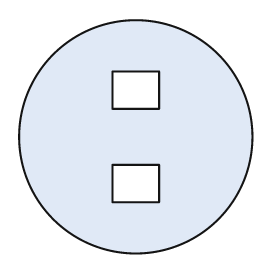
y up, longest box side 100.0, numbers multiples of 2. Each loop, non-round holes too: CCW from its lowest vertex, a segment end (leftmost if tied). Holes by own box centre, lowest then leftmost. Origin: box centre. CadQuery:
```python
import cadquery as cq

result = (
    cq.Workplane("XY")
    .moveTo(0.0, 0.0)
    .circle(50.0)
    .moveTo(-10.0, -28.0)
    .lineTo(10.0, -28.0)
    .lineTo(10.0, -12.0)
    .lineTo(-10.0, -12.0)
    .close()
    .moveTo(-10.0, 12.0)
    .lineTo(10.0, 12.0)
    .lineTo(10.0, 28.0)
    .lineTo(-10.0, 28.0)
    .close()
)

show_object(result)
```